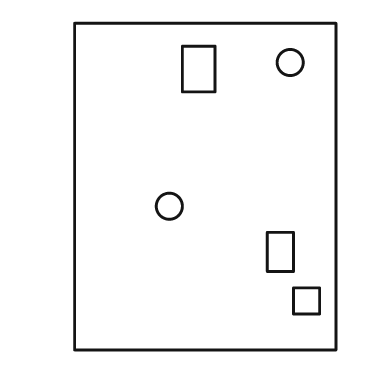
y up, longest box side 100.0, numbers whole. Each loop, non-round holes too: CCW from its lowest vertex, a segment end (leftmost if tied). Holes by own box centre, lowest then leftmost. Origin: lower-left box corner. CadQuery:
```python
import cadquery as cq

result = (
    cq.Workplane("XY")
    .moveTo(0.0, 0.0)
    .lineTo(80.0, 0.0)
    .lineTo(80.0, 100.0)
    .lineTo(0.0, 100.0)
    .close()
    .moveTo(67.0, 11.0)
    .lineTo(75.0, 11.0)
    .lineTo(75.0, 19.0)
    .lineTo(67.0, 19.0)
    .close()
    .moveTo(59.0, 24.0)
    .lineTo(67.0, 24.0)
    .lineTo(67.0, 36.0)
    .lineTo(59.0, 36.0)
    .close()
    .moveTo(29.0, 44.0)
    .circle(4.0)
    .moveTo(33.0, 79.0)
    .lineTo(43.0, 79.0)
    .lineTo(43.0, 93.0)
    .lineTo(33.0, 93.0)
    .close()
    .moveTo(66.0, 88.0)
    .circle(4.0)
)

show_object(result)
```